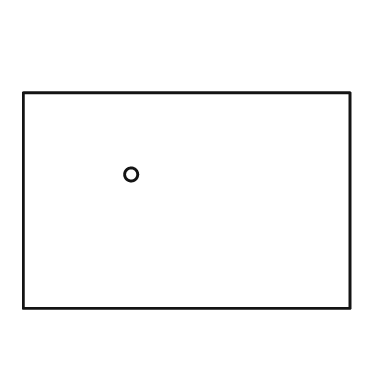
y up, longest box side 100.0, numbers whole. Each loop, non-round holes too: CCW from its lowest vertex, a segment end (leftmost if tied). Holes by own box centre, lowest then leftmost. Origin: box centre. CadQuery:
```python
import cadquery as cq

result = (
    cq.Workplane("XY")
    .moveTo(-50.0, -33.0)
    .lineTo(50.0, -33.0)
    .lineTo(50.0, 33.0)
    .lineTo(-50.0, 33.0)
    .close()
    .moveTo(-17.0, 8.0)
    .circle(2.0)
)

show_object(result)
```